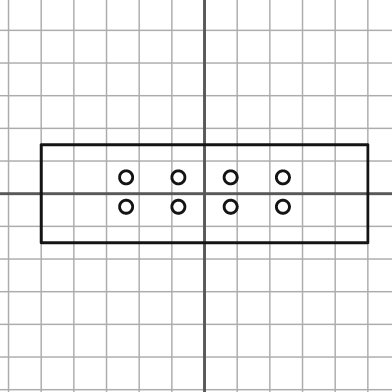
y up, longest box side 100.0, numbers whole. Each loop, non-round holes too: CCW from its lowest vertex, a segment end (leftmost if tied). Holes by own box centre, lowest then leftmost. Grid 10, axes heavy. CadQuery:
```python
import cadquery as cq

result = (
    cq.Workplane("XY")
    .moveTo(-50.0, -15.0)
    .lineTo(50.0, -15.0)
    .lineTo(50.0, 15.0)
    .lineTo(-50.0, 15.0)
    .close()
    .moveTo(-24.0, -4.0)
    .circle(2.0)
    .moveTo(-8.0, -4.0)
    .circle(2.0)
    .moveTo(8.0, -4.0)
    .circle(2.0)
    .moveTo(24.0, -4.0)
    .circle(2.0)
    .moveTo(-24.0, 5.0)
    .circle(2.0)
    .moveTo(-8.0, 5.0)
    .circle(2.0)
    .moveTo(8.0, 5.0)
    .circle(2.0)
    .moveTo(24.0, 5.0)
    .circle(2.0)
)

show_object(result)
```